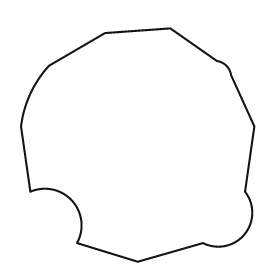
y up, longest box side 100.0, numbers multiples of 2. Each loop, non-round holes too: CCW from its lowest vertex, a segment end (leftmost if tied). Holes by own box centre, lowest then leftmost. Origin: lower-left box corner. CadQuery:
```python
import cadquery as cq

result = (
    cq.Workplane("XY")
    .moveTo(50.0, 0.0)
    .lineTo(78.0, 8.0)
    .threePointArc((96.0, 12.0), (96.0, 30.0))
    .lineTo(100.0, 58.0)
    .lineTo(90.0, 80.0)
    .threePointArc((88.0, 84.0), (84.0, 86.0))
    .lineTo(64.0, 100.0)
    .lineTo(36.0, 98.0)
    .lineTo(12.0, 84.0)
    .threePointArc((4.0, 72.0), (0.0, 58.0))
    .lineTo(4.0, 30.0)
    .threePointArc((22.0, 26.0), (24.0, 8.0))
    .close()
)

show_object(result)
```